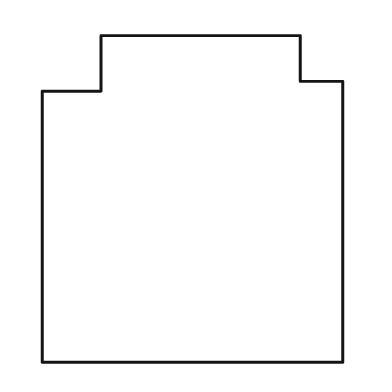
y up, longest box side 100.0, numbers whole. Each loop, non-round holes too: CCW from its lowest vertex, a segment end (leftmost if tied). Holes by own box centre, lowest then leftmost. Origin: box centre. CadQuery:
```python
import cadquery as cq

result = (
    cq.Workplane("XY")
    .moveTo(-46.0, -50.0)
    .lineTo(46.0, -50.0)
    .lineTo(46.0, 36.0)
    .lineTo(33.0, 36.0)
    .lineTo(33.0, 50.0)
    .lineTo(-28.0, 50.0)
    .lineTo(-28.0, 33.0)
    .lineTo(-46.0, 33.0)
    .close()
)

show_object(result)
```